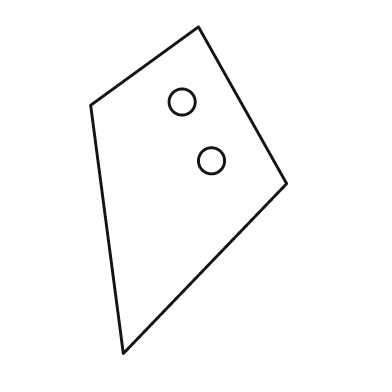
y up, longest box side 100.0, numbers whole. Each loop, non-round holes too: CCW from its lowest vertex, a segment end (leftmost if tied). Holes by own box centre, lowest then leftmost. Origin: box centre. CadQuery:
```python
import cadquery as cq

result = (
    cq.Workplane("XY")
    .moveTo(-20.0, -50.0)
    .lineTo(30.0, 2.0)
    .lineTo(3.0, 50.0)
    .lineTo(-30.0, 26.0)
    .close()
    .moveTo(7.0, 9.0)
    .circle(4.0)
    .moveTo(-2.0, 27.0)
    .circle(4.0)
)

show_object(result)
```